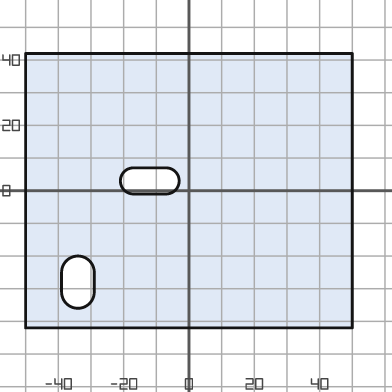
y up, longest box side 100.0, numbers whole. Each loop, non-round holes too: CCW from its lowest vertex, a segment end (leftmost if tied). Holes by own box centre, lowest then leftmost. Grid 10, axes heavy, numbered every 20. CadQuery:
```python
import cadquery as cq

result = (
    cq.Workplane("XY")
    .moveTo(-50.0, -42.0)
    .lineTo(50.0, -42.0)
    .lineTo(50.0, 42.0)
    .lineTo(-50.0, 42.0)
    .close()
    .moveTo(-39.0, -31.0)
    .threePointArc((-34.0, -36.0), (-29.0, -31.0))
    .lineTo(-29.0, -25.0)
    .threePointArc((-34.0, -20.0), (-39.0, -25.0))
    .close()
    .moveTo(-17.0, -1.0)
    .lineTo(-7.0, -1.0)
    .threePointArc((-3.0, 3.0), (-7.0, 7.0))
    .lineTo(-17.0, 7.0)
    .threePointArc((-21.0, 3.0), (-17.0, -1.0))
    .close()
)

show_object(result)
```